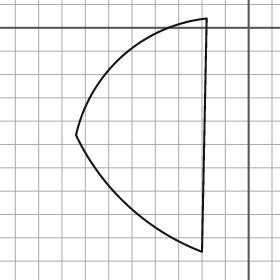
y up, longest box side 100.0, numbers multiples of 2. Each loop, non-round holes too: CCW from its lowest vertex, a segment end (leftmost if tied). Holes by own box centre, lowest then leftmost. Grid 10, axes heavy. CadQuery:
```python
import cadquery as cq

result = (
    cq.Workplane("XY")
    .moveTo(-20.0, -96.0)
    .lineTo(-18.0, 4.0)
    .threePointArc((-54.0, -12.0), (-74.0, -46.0))
    .threePointArc((-52.0, -76.0), (-20.0, -96.0))
    .close()
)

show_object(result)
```